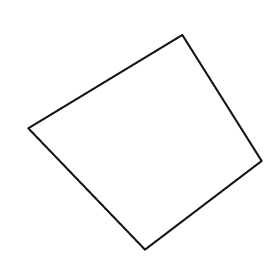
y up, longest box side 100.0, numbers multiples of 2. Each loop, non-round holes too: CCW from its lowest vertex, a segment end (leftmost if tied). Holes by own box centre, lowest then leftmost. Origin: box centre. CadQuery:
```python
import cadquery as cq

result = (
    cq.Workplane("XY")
    .moveTo(0.0, -46.0)
    .lineTo(50.0, -8.0)
    .lineTo(16.0, 46.0)
    .lineTo(-50.0, 6.0)
    .close()
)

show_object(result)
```